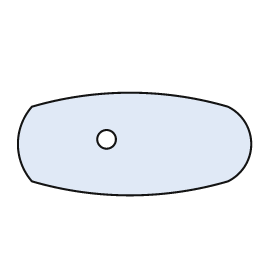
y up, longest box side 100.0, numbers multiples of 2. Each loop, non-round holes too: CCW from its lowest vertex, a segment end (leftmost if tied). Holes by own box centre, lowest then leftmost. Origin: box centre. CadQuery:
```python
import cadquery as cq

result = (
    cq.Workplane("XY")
    .moveTo(-44.0, -16.0)
    .threePointArc((-2.0, -22.0), (40.0, -16.0))
    .threePointArc((50.0, 0.0), (40.0, 16.0))
    .threePointArc((-2.0, 22.0), (-44.0, 16.0))
    .threePointArc((-50.0, 0.0), (-44.0, -16.0))
    .close()
    .moveTo(-12.0, 2.0)
    .circle(4.0)
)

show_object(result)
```